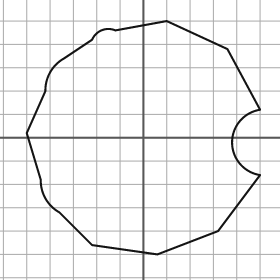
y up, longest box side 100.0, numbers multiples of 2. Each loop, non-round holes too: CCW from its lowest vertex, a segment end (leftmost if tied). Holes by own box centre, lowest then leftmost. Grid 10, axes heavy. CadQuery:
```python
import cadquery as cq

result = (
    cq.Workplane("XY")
    .moveTo(6.0, -50.0)
    .lineTo(32.0, -40.0)
    .lineTo(50.0, -16.0)
    .threePointArc((38.0, -2.0), (50.0, 12.0))
    .lineTo(36.0, 38.0)
    .lineTo(10.0, 50.0)
    .lineTo(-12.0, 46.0)
    .threePointArc((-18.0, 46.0), (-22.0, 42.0))
    .lineTo(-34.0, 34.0)
    .threePointArc((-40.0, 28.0), (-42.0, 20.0))
    .lineTo(-50.0, 2.0)
    .lineTo(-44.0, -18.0)
    .threePointArc((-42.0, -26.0), (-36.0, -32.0))
    .lineTo(-22.0, -46.0)
    .close()
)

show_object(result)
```